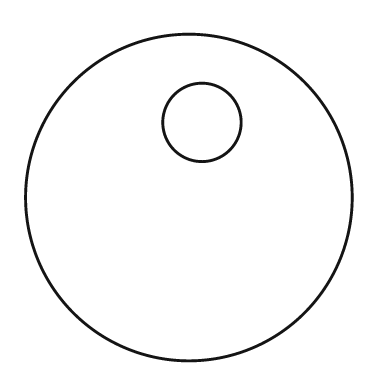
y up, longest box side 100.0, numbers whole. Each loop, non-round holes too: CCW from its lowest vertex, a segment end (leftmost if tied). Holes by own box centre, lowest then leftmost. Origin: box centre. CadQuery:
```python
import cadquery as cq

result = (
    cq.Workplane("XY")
    .moveTo(0.0, 0.0)
    .circle(50.0)
    .moveTo(4.0, 23.0)
    .circle(12.0)
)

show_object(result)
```